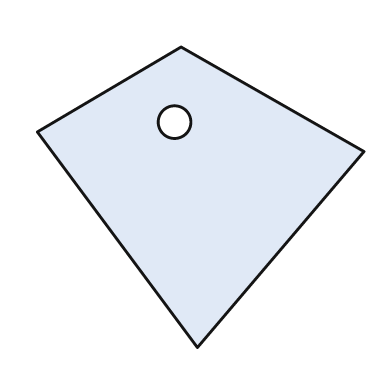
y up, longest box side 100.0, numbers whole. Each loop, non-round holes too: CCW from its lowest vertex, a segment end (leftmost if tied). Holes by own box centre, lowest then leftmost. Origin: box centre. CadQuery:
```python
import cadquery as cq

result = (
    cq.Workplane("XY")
    .moveTo(-1.0, -46.0)
    .lineTo(50.0, 14.0)
    .lineTo(-6.0, 46.0)
    .lineTo(-50.0, 20.0)
    .close()
    .moveTo(-8.0, 23.0)
    .circle(5.0)
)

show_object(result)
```